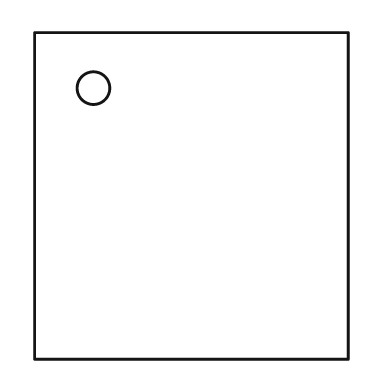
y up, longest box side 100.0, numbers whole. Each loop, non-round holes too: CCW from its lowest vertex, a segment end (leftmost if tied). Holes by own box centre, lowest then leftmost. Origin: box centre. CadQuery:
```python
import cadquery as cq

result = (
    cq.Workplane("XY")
    .moveTo(-48.0, -50.0)
    .lineTo(48.0, -50.0)
    .lineTo(48.0, 50.0)
    .lineTo(-48.0, 50.0)
    .close()
    .moveTo(-30.0, 33.0)
    .circle(5.0)
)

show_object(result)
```